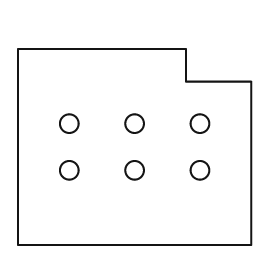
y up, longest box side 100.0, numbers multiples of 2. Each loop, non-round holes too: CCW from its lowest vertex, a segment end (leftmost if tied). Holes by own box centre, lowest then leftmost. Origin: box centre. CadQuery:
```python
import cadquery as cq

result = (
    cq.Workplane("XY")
    .moveTo(-50.0, -42.0)
    .lineTo(50.0, -42.0)
    .lineTo(50.0, 28.0)
    .lineTo(22.0, 28.0)
    .lineTo(22.0, 42.0)
    .lineTo(-50.0, 42.0)
    .close()
    .moveTo(-28.0, -10.0)
    .circle(4.0)
    .moveTo(0.0, -10.0)
    .circle(4.0)
    .moveTo(28.0, -10.0)
    .circle(4.0)
    .moveTo(-28.0, 10.0)
    .circle(4.0)
    .moveTo(0.0, 10.0)
    .circle(4.0)
    .moveTo(28.0, 10.0)
    .circle(4.0)
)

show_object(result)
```